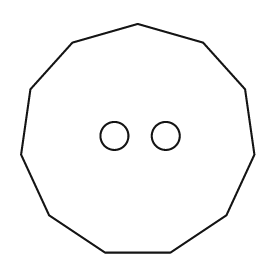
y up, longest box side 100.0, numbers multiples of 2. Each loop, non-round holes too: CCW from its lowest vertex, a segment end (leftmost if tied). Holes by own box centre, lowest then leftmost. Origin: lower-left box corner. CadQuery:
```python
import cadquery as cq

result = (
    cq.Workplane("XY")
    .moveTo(36.0, 0.0)
    .lineTo(64.0, 0.0)
    .lineTo(88.0, 16.0)
    .lineTo(100.0, 42.0)
    .lineTo(96.0, 70.0)
    .lineTo(78.0, 90.0)
    .lineTo(50.0, 98.0)
    .lineTo(22.0, 90.0)
    .lineTo(4.0, 70.0)
    .lineTo(0.0, 42.0)
    .lineTo(12.0, 16.0)
    .close()
    .moveTo(40.0, 50.0)
    .circle(6.0)
    .moveTo(62.0, 50.0)
    .circle(6.0)
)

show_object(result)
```